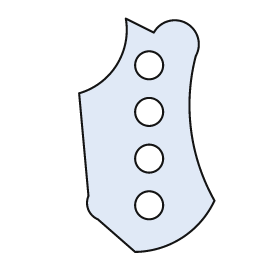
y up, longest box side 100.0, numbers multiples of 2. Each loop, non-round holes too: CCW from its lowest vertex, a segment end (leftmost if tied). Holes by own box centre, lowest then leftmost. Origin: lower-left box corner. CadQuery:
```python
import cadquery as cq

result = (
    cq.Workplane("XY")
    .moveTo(24.0, 0.0)
    .threePointArc((44.0, 6.0), (58.0, 22.0))
    .threePointArc((48.0, 52.0), (50.0, 84.0))
    .threePointArc((46.0, 98.0), (32.0, 94.0))
    .lineTo(20.0, 100.0)
    .threePointArc((16.0, 80.0), (0.0, 68.0))
    .lineTo(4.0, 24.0)
    .threePointArc((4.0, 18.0), (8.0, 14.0))
    .close()
    .moveTo(30.0, 20.0)
    .circle(6.0)
    .moveTo(30.0, 40.0)
    .circle(6.0)
    .moveTo(30.0, 60.0)
    .circle(6.0)
    .moveTo(30.0, 80.0)
    .circle(6.0)
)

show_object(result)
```